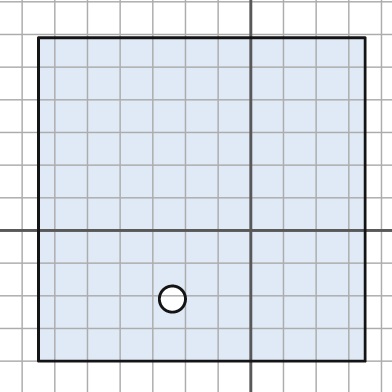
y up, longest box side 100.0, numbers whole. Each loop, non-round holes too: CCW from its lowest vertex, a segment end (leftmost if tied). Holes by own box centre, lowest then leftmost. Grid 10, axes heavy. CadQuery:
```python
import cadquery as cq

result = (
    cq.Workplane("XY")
    .moveTo(-65.0, -40.0)
    .lineTo(35.0, -40.0)
    .lineTo(35.0, 59.0)
    .lineTo(-65.0, 59.0)
    .close()
    .moveTo(-24.0, -21.0)
    .circle(4.0)
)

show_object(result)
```